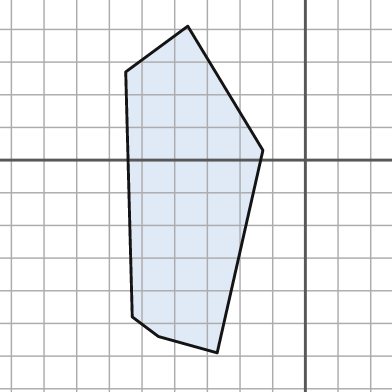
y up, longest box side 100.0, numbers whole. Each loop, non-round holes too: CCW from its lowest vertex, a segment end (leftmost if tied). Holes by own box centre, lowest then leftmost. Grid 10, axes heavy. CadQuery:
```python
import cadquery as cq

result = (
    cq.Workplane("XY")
    .moveTo(-27.0, -59.0)
    .lineTo(-13.0, 3.0)
    .lineTo(-36.0, 41.0)
    .lineTo(-55.0, 27.0)
    .lineTo(-53.0, -48.0)
    .lineTo(-45.0, -54.0)
    .close()
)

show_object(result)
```